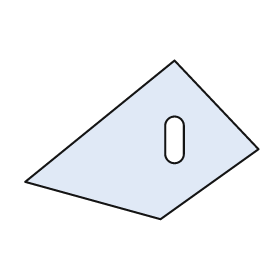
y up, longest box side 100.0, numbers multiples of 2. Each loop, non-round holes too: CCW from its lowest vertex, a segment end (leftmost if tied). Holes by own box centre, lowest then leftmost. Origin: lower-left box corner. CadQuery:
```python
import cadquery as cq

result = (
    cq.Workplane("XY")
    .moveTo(58.0, 0.0)
    .lineTo(100.0, 30.0)
    .lineTo(64.0, 68.0)
    .lineTo(0.0, 16.0)
    .close()
    .moveTo(60.0, 28.0)
    .threePointArc((64.0, 24.0), (68.0, 28.0))
    .lineTo(68.0, 40.0)
    .threePointArc((64.0, 44.0), (60.0, 40.0))
    .close()
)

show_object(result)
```